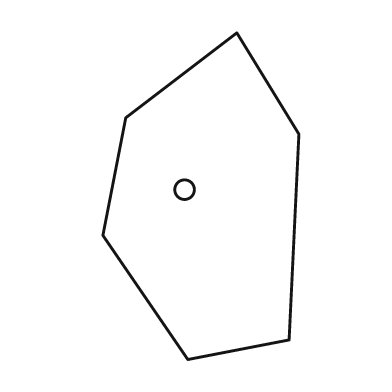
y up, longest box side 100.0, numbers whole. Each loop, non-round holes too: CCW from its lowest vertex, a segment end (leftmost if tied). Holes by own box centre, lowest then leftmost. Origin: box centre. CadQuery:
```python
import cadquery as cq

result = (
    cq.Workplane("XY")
    .moveTo(-4.0, -50.0)
    .lineTo(27.0, -44.0)
    .lineTo(30.0, 19.0)
    .lineTo(11.0, 50.0)
    .lineTo(-23.0, 24.0)
    .lineTo(-30.0, -12.0)
    .close()
    .moveTo(-5.0, 2.0)
    .circle(3.0)
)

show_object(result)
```